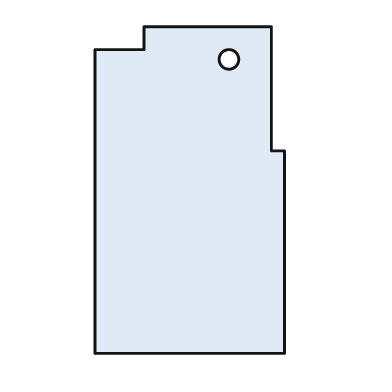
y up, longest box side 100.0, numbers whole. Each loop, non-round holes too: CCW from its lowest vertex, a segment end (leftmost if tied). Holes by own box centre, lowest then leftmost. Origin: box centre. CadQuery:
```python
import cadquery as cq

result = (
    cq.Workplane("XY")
    .moveTo(-29.0, -50.0)
    .lineTo(29.0, -50.0)
    .lineTo(29.0, 12.0)
    .lineTo(25.0, 12.0)
    .lineTo(25.0, 50.0)
    .lineTo(-14.0, 50.0)
    .lineTo(-14.0, 43.0)
    .lineTo(-29.0, 43.0)
    .close()
    .moveTo(12.0, 40.0)
    .circle(3.0)
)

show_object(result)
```